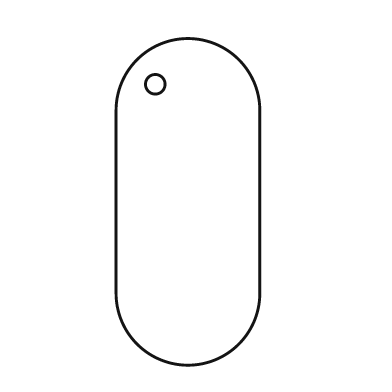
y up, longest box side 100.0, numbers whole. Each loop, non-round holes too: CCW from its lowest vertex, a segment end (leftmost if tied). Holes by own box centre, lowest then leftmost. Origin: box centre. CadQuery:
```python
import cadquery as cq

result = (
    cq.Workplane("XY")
    .moveTo(-22.0, -28.0)
    .threePointArc((0.0, -50.0), (22.0, -28.0))
    .lineTo(22.0, 28.0)
    .threePointArc((0.0, 50.0), (-22.0, 28.0))
    .close()
    .moveTo(-10.0, 36.0)
    .circle(3.0)
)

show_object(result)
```